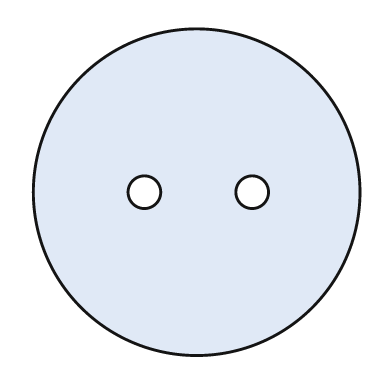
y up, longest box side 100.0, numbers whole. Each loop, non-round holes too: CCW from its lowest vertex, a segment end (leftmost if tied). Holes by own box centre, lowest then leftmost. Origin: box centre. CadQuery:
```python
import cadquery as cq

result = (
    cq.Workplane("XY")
    .moveTo(0.0, 0.0)
    .circle(50.0)
    .moveTo(-16.0, 0.0)
    .circle(5.0)
    .moveTo(17.0, 0.0)
    .circle(5.0)
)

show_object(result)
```